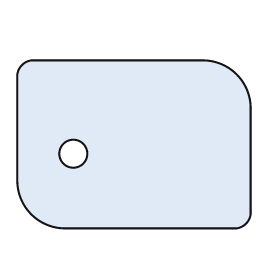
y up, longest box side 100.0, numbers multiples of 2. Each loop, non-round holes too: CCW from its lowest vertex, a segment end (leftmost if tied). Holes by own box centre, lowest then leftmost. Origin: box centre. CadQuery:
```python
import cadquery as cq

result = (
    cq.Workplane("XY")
    .moveTo(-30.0, -36.0)
    .lineTo(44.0, -36.0)
    .threePointArc((48.0, -34.0), (50.0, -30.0))
    .lineTo(50.0, 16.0)
    .threePointArc((44.0, 30.0), (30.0, 36.0))
    .lineTo(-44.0, 36.0)
    .threePointArc((-48.0, 34.0), (-50.0, 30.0))
    .lineTo(-50.0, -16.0)
    .threePointArc((-44.0, -30.0), (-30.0, -36.0))
    .close()
    .moveTo(-26.0, -4.0)
    .circle(6.0)
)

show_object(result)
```